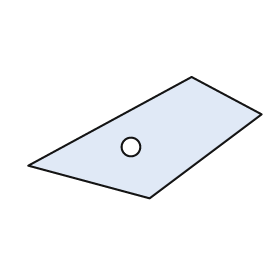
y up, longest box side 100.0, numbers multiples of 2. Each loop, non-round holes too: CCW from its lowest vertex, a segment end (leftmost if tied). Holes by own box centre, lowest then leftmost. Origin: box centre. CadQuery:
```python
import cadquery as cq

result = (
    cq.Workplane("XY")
    .moveTo(2.0, -26.0)
    .lineTo(50.0, 10.0)
    .lineTo(20.0, 26.0)
    .lineTo(-50.0, -12.0)
    .close()
    .moveTo(-6.0, -4.0)
    .circle(4.0)
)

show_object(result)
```